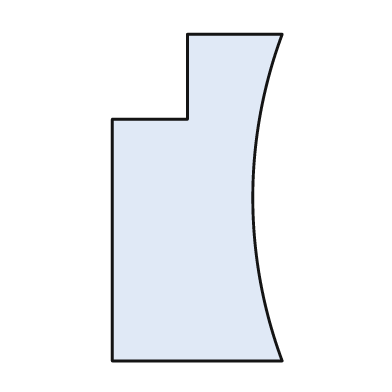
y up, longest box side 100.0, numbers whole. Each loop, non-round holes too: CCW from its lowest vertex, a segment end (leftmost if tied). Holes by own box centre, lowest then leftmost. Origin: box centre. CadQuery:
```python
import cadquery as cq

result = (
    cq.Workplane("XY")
    .moveTo(-26.0, -50.0)
    .lineTo(26.0, -50.0)
    .threePointArc((17.0, 0.0), (26.0, 50.0))
    .lineTo(-3.0, 50.0)
    .lineTo(-3.0, 24.0)
    .lineTo(-26.0, 24.0)
    .close()
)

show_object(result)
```